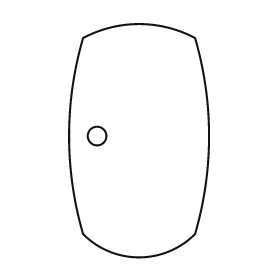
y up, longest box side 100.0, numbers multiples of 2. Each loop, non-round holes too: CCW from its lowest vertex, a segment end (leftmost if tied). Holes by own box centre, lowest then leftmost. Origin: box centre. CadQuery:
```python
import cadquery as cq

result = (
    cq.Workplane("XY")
    .moveTo(-24.0, -40.0)
    .threePointArc((0.0, -50.0), (24.0, -40.0))
    .threePointArc((30.0, 2.0), (24.0, 44.0))
    .threePointArc((0.0, 50.0), (-24.0, 44.0))
    .threePointArc((-30.0, 2.0), (-24.0, -40.0))
    .close()
    .moveTo(-18.0, 2.0)
    .circle(4.0)
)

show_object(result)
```